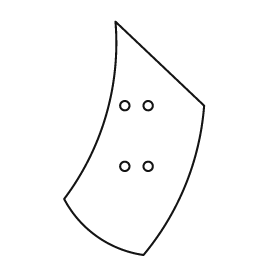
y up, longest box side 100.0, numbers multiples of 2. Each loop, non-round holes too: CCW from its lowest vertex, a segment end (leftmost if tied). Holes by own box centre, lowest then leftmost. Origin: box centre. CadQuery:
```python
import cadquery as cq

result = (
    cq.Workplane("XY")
    .moveTo(4.0, -50.0)
    .threePointArc((22.0, -20.0), (30.0, 14.0))
    .lineTo(-8.0, 50.0)
    .threePointArc((-12.0, 10.0), (-30.0, -26.0))
    .threePointArc((-16.0, -42.0), (4.0, -50.0))
    .close()
    .moveTo(-4.0, -12.0)
    .circle(2.0)
    .moveTo(6.0, -12.0)
    .circle(2.0)
    .moveTo(-4.0, 14.0)
    .circle(2.0)
    .moveTo(6.0, 14.0)
    .circle(2.0)
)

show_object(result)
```